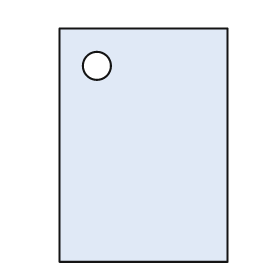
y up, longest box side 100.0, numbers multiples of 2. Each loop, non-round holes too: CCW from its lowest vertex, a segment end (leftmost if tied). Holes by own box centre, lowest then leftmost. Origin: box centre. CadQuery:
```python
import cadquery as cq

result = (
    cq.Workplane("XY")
    .moveTo(-36.0, -50.0)
    .lineTo(36.0, -50.0)
    .lineTo(36.0, 50.0)
    .lineTo(-36.0, 50.0)
    .close()
    .moveTo(-20.0, 34.0)
    .circle(6.0)
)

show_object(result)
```